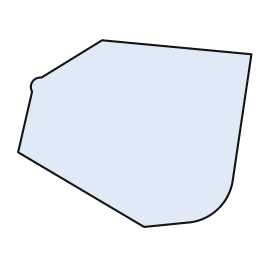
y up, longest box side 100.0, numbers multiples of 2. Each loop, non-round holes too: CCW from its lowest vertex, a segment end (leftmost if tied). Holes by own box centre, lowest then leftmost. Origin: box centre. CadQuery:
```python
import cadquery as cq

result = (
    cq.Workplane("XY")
    .moveTo(4.0, -40.0)
    .lineTo(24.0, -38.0)
    .threePointArc((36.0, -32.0), (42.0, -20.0))
    .lineTo(50.0, 34.0)
    .lineTo(-14.0, 40.0)
    .lineTo(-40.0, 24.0)
    .threePointArc((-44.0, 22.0), (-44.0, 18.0))
    .lineTo(-50.0, -8.0)
    .close()
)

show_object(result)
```